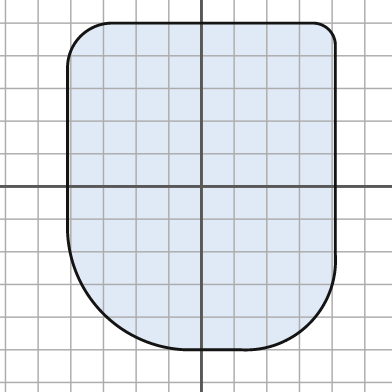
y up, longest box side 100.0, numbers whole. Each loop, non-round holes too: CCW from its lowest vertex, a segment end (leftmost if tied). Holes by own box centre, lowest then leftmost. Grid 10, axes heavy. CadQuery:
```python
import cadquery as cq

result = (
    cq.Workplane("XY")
    .moveTo(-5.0, -50.0)
    .lineTo(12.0, -50.0)
    .threePointArc((33.0, -42.0), (41.0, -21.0))
    .lineTo(41.0, 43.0)
    .threePointArc((39.0, 48.0), (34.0, 50.0))
    .lineTo(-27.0, 50.0)
    .threePointArc((-37.0, 46.0), (-41.0, 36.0))
    .lineTo(-41.0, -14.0)
    .threePointArc((-30.0, -39.0), (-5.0, -50.0))
    .close()
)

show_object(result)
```